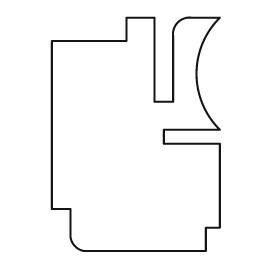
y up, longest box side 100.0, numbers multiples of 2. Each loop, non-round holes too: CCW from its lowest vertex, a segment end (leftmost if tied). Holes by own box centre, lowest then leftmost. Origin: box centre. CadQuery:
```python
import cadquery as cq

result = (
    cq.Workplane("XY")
    .moveTo(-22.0, -50.0)
    .lineTo(30.0, -50.0)
    .lineTo(30.0, -40.0)
    .lineTo(36.0, -40.0)
    .lineTo(36.0, -4.0)
    .lineTo(12.0, -4.0)
    .lineTo(12.0, 2.0)
    .lineTo(36.0, 2.0)
    .threePointArc((26.0, 26.0), (36.0, 50.0))
    .lineTo(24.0, 50.0)
    .threePointArc((18.0, 48.0), (16.0, 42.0))
    .lineTo(16.0, 14.0)
    .lineTo(8.0, 14.0)
    .lineTo(8.0, 50.0)
    .lineTo(-4.0, 50.0)
    .lineTo(-4.0, 40.0)
    .lineTo(-36.0, 40.0)
    .lineTo(-36.0, -32.0)
    .lineTo(-28.0, -32.0)
    .lineTo(-28.0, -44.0)
    .threePointArc((-26.0, -48.0), (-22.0, -50.0))
    .close()
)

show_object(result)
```